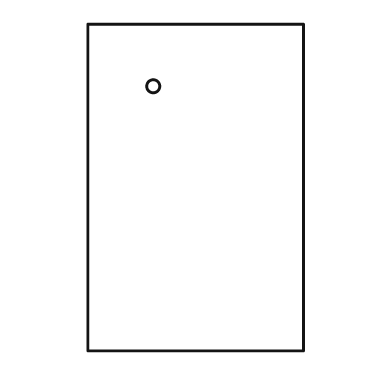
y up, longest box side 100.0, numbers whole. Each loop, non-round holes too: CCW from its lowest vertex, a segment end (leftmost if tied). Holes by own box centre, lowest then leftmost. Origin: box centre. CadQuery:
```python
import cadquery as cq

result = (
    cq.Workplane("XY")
    .moveTo(-33.0, -50.0)
    .lineTo(33.0, -50.0)
    .lineTo(33.0, 50.0)
    .lineTo(-33.0, 50.0)
    .close()
    .moveTo(-13.0, 31.0)
    .circle(2.0)
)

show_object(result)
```